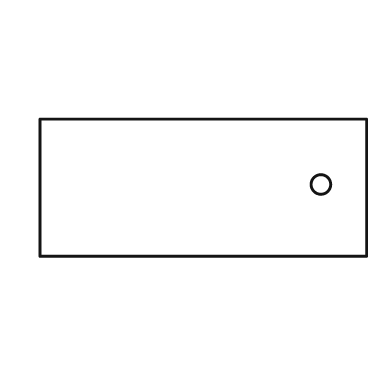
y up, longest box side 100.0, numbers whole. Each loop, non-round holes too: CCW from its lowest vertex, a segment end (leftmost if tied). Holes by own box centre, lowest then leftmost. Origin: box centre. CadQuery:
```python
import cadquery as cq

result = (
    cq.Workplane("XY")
    .moveTo(-50.0, -21.0)
    .lineTo(50.0, -21.0)
    .lineTo(50.0, 21.0)
    .lineTo(-50.0, 21.0)
    .close()
    .moveTo(36.0, 1.0)
    .circle(3.0)
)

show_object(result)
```